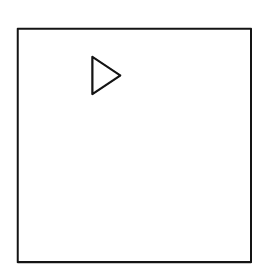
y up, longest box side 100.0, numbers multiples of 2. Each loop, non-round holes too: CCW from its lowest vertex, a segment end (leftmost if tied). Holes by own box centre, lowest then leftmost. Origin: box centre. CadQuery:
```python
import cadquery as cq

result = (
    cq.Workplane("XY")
    .moveTo(-50.0, -50.0)
    .lineTo(50.0, -50.0)
    .lineTo(50.0, 50.0)
    .lineTo(-50.0, 50.0)
    .close()
    .moveTo(-18.0, 22.0)
    .lineTo(-6.0, 30.0)
    .lineTo(-18.0, 38.0)
    .close()
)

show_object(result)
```